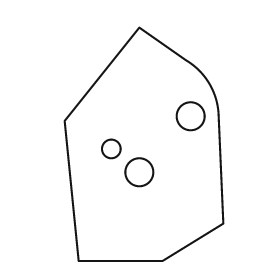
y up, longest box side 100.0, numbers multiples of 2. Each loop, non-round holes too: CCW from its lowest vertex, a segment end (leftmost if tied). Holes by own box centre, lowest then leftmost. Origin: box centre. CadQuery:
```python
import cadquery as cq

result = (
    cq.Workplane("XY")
    .moveTo(-28.0, -50.0)
    .lineTo(8.0, -50.0)
    .lineTo(34.0, -34.0)
    .lineTo(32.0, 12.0)
    .threePointArc((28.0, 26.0), (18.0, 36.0))
    .lineTo(-2.0, 50.0)
    .lineTo(-34.0, 10.0)
    .close()
    .moveTo(-2.0, -12.0)
    .circle(6.0)
    .moveTo(-14.0, -2.0)
    .circle(4.0)
    .moveTo(20.0, 12.0)
    .circle(6.0)
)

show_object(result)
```